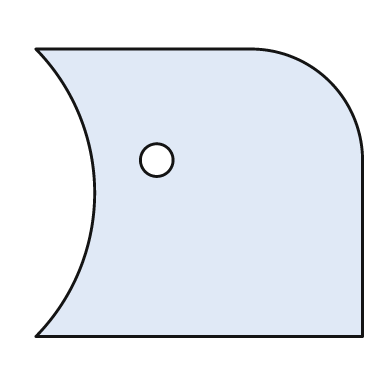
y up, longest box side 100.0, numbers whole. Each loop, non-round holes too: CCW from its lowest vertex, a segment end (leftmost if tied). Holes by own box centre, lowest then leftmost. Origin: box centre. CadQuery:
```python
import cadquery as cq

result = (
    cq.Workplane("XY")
    .moveTo(-50.0, -44.0)
    .lineTo(50.0, -44.0)
    .lineTo(50.0, 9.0)
    .threePointArc((40.0, 34.0), (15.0, 44.0))
    .lineTo(-50.0, 44.0)
    .threePointArc((-32.0, 0.0), (-50.0, -44.0))
    .close()
    .moveTo(-13.0, 10.0)
    .circle(5.0)
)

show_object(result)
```